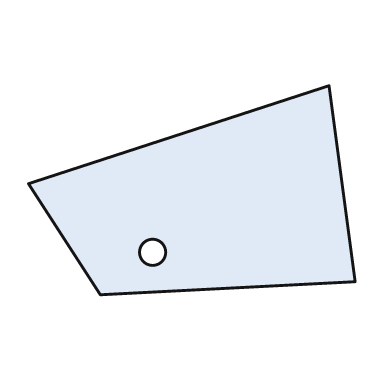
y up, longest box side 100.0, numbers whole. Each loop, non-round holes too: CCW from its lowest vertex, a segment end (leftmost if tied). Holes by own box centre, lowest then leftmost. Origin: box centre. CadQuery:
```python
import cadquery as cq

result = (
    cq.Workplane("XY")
    .moveTo(-28.0, -32.0)
    .lineTo(50.0, -28.0)
    .lineTo(42.0, 32.0)
    .lineTo(-50.0, 2.0)
    .close()
    .moveTo(-12.0, -19.0)
    .circle(4.0)
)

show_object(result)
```